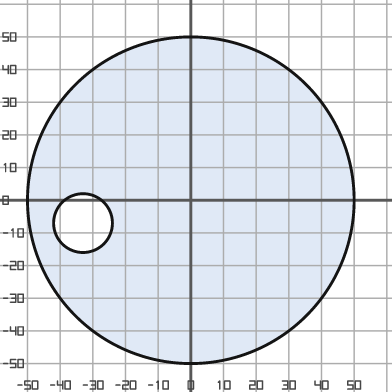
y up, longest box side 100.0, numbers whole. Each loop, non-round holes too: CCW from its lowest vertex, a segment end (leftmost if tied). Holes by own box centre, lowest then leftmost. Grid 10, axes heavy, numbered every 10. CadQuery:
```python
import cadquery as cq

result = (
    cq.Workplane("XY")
    .moveTo(0.0, 0.0)
    .circle(50.0)
    .moveTo(-33.0, -7.0)
    .circle(9.0)
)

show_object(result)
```